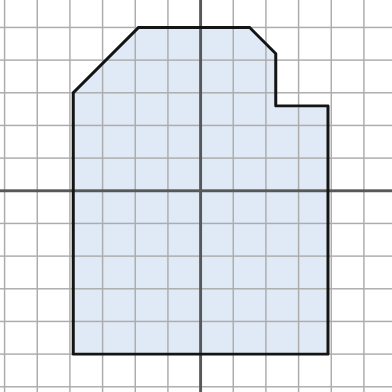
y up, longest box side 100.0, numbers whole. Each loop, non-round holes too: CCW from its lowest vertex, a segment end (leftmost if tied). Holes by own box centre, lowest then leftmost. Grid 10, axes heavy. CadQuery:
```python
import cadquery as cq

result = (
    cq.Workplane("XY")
    .moveTo(-39.0, -50.0)
    .lineTo(39.0, -50.0)
    .lineTo(39.0, 26.0)
    .lineTo(23.0, 26.0)
    .lineTo(23.0, 42.0)
    .lineTo(15.0, 50.0)
    .lineTo(-19.0, 50.0)
    .lineTo(-39.0, 30.0)
    .close()
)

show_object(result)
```